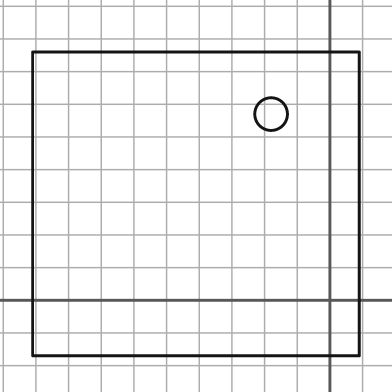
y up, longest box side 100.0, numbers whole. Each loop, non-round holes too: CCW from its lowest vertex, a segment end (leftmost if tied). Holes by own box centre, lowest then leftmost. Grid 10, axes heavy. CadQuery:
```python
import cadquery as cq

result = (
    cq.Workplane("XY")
    .moveTo(-91.0, -17.0)
    .lineTo(9.0, -17.0)
    .lineTo(9.0, 76.0)
    .lineTo(-91.0, 76.0)
    .close()
    .moveTo(-18.0, 57.0)
    .circle(5.0)
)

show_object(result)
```